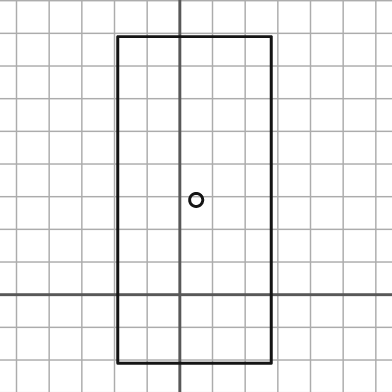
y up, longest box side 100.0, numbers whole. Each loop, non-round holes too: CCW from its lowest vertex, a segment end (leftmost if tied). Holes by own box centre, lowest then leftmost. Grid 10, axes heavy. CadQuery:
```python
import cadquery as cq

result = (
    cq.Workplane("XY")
    .moveTo(-19.0, -21.0)
    .lineTo(28.0, -21.0)
    .lineTo(28.0, 79.0)
    .lineTo(-19.0, 79.0)
    .close()
    .moveTo(5.0, 29.0)
    .circle(2.0)
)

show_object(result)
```